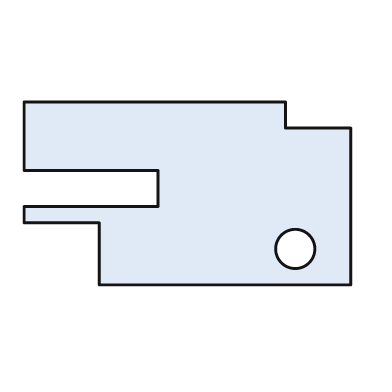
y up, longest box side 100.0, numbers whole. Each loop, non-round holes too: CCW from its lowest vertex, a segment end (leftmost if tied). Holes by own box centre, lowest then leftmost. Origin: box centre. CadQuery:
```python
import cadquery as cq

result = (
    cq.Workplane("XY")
    .moveTo(-27.0, -28.0)
    .lineTo(50.0, -28.0)
    .lineTo(50.0, 20.0)
    .lineTo(30.0, 20.0)
    .lineTo(30.0, 28.0)
    .lineTo(-50.0, 28.0)
    .lineTo(-50.0, 7.0)
    .lineTo(-9.0, 7.0)
    .lineTo(-9.0, -4.0)
    .lineTo(-50.0, -4.0)
    .lineTo(-50.0, -9.0)
    .lineTo(-27.0, -9.0)
    .close()
    .moveTo(33.0, -17.0)
    .circle(6.0)
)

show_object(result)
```